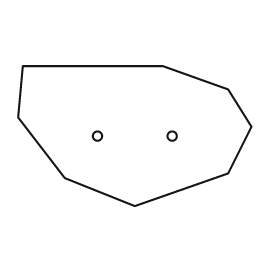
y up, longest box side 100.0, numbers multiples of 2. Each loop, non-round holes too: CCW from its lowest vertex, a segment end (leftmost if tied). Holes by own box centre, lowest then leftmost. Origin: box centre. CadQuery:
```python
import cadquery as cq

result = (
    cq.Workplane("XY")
    .moveTo(0.0, -30.0)
    .lineTo(40.0, -16.0)
    .lineTo(50.0, 4.0)
    .lineTo(40.0, 20.0)
    .lineTo(12.0, 30.0)
    .lineTo(-48.0, 30.0)
    .lineTo(-50.0, 8.0)
    .lineTo(-30.0, -18.0)
    .close()
    .moveTo(-16.0, 0.0)
    .circle(2.0)
    .moveTo(16.0, 0.0)
    .circle(2.0)
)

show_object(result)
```